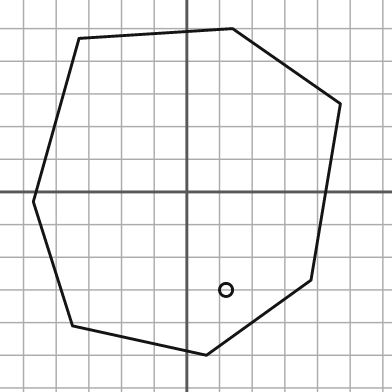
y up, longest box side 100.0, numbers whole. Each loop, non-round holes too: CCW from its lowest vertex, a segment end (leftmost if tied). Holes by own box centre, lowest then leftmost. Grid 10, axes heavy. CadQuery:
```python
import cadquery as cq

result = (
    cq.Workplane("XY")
    .moveTo(6.0, -50.0)
    .lineTo(38.0, -27.0)
    .lineTo(47.0, 27.0)
    .lineTo(14.0, 50.0)
    .lineTo(-33.0, 47.0)
    .lineTo(-47.0, -3.0)
    .lineTo(-35.0, -41.0)
    .close()
    .moveTo(12.0, -30.0)
    .circle(2.0)
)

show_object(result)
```